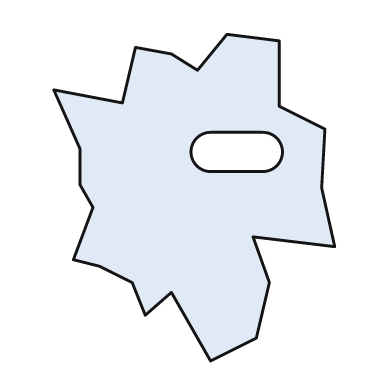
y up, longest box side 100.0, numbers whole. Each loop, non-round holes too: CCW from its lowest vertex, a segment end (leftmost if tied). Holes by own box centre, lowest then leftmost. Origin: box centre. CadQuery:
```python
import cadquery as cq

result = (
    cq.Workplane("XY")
    .moveTo(5.0, -50.0)
    .lineTo(19.0, -43.0)
    .lineTo(23.0, -26.0)
    .lineTo(18.0, -12.0)
    .lineTo(43.0, -15.0)
    .lineTo(39.0, 3.0)
    .lineTo(40.0, 21.0)
    .lineTo(26.0, 28.0)
    .lineTo(26.0, 48.0)
    .lineTo(10.0, 50.0)
    .lineTo(1.0, 39.0)
    .lineTo(-7.0, 44.0)
    .lineTo(-18.0, 46.0)
    .lineTo(-22.0, 29.0)
    .lineTo(-43.0, 33.0)
    .lineTo(-35.0, 15.0)
    .lineTo(-35.0, 4.0)
    .lineTo(-31.0, -3.0)
    .lineTo(-37.0, -19.0)
    .lineTo(-29.0, -21.0)
    .lineTo(-19.0, -26.0)
    .lineTo(-15.0, -36.0)
    .lineTo(-7.0, -29.0)
    .close()
    .moveTo(5.0, 8.0)
    .lineTo(21.0, 8.0)
    .threePointArc((27.0, 14.0), (21.0, 20.0))
    .lineTo(5.0, 20.0)
    .threePointArc((-1.0, 14.0), (5.0, 8.0))
    .close()
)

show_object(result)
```